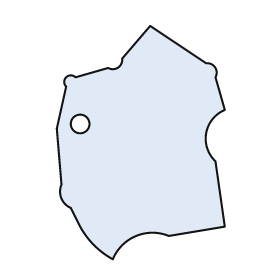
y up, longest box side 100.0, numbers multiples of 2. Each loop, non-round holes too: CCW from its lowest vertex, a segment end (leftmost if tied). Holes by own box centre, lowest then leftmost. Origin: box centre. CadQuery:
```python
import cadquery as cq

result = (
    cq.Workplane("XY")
    .moveTo(-12.0, -50.0)
    .threePointArc((-2.0, -40.0), (12.0, -40.0))
    .lineTo(36.0, -36.0)
    .lineTo(32.0, -8.0)
    .threePointArc((28.0, 4.0), (36.0, 14.0))
    .lineTo(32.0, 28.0)
    .threePointArc((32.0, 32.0), (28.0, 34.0))
    .lineTo(4.0, 50.0)
    .lineTo(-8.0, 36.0)
    .threePointArc((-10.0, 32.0), (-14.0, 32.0))
    .lineTo(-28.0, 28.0)
    .threePointArc((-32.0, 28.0), (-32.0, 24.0))
    .lineTo(-36.0, 6.0)
    .lineTo(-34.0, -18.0)
    .threePointArc((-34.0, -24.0), (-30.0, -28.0))
    .lineTo(-26.0, -36.0)
    .threePointArc((-20.0, -44.0), (-12.0, -50.0))
    .close()
    .moveTo(-26.0, 8.0)
    .circle(4.0)
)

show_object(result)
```